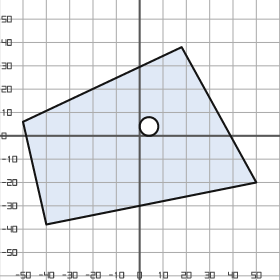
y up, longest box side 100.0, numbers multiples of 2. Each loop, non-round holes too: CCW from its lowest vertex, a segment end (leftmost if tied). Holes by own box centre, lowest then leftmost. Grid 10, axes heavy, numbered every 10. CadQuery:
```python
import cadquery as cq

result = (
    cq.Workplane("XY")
    .moveTo(-40.0, -38.0)
    .lineTo(50.0, -20.0)
    .lineTo(18.0, 38.0)
    .lineTo(-50.0, 6.0)
    .close()
    .moveTo(4.0, 4.0)
    .circle(4.0)
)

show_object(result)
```